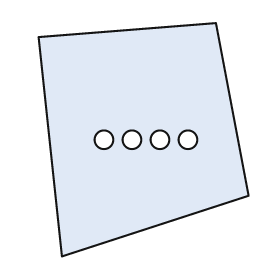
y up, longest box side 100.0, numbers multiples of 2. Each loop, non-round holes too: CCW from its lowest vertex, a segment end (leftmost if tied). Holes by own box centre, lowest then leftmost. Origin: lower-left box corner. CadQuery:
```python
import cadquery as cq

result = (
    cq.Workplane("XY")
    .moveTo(10.0, 0.0)
    .lineTo(90.0, 26.0)
    .lineTo(76.0, 100.0)
    .lineTo(0.0, 94.0)
    .close()
    .moveTo(28.0, 50.0)
    .circle(4.0)
    .moveTo(40.0, 50.0)
    .circle(4.0)
    .moveTo(52.0, 50.0)
    .circle(4.0)
    .moveTo(64.0, 50.0)
    .circle(4.0)
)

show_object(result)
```